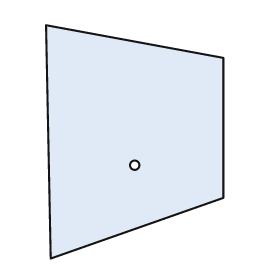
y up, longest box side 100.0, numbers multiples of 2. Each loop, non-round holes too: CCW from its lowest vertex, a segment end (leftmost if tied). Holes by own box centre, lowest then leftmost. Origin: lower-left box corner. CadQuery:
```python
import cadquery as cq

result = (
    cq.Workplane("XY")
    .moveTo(2.0, 0.0)
    .lineTo(76.0, 26.0)
    .lineTo(76.0, 86.0)
    .lineTo(0.0, 100.0)
    .close()
    .moveTo(38.0, 40.0)
    .circle(2.0)
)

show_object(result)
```